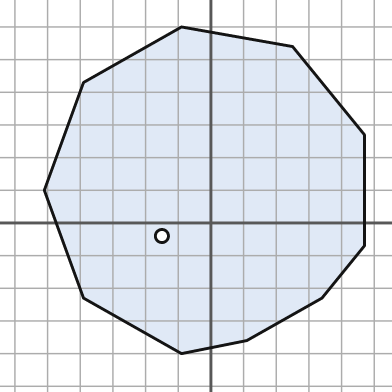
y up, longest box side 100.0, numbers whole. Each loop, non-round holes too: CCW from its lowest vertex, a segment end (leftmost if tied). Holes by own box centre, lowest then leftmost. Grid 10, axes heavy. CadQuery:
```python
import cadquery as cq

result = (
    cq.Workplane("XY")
    .moveTo(-9.0, -40.0)
    .lineTo(11.0, -36.0)
    .lineTo(34.0, -23.0)
    .lineTo(47.0, -7.0)
    .lineTo(47.0, 27.0)
    .lineTo(25.0, 54.0)
    .lineTo(-9.0, 60.0)
    .lineTo(-39.0, 43.0)
    .lineTo(-51.0, 10.0)
    .lineTo(-39.0, -23.0)
    .close()
    .moveTo(-15.0, -4.0)
    .circle(2.0)
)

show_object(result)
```